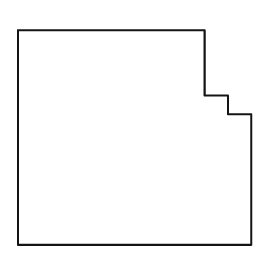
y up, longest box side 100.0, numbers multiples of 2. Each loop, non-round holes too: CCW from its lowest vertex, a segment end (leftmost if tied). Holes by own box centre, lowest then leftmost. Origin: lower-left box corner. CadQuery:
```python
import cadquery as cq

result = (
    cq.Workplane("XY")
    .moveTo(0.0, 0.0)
    .lineTo(100.0, 0.0)
    .lineTo(100.0, 56.0)
    .lineTo(90.0, 56.0)
    .lineTo(90.0, 64.0)
    .lineTo(80.0, 64.0)
    .lineTo(80.0, 92.0)
    .lineTo(0.0, 92.0)
    .close()
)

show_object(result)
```